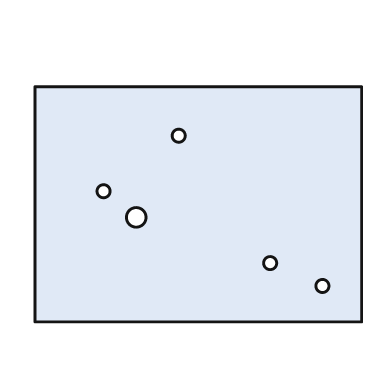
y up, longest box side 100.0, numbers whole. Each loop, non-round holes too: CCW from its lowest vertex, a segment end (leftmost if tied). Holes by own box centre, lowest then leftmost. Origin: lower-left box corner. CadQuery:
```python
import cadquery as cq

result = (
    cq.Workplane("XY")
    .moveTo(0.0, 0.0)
    .lineTo(100.0, 0.0)
    .lineTo(100.0, 72.0)
    .lineTo(0.0, 72.0)
    .close()
    .moveTo(88.0, 11.0)
    .circle(2.0)
    .moveTo(72.0, 18.0)
    .circle(2.0)
    .moveTo(31.0, 32.0)
    .circle(3.0)
    .moveTo(21.0, 40.0)
    .circle(2.0)
    .moveTo(44.0, 57.0)
    .circle(2.0)
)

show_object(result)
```